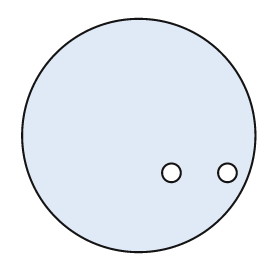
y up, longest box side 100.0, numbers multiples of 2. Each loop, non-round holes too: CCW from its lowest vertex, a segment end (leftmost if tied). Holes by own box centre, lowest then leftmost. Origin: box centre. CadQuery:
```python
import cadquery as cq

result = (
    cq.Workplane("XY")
    .moveTo(0.0, 0.0)
    .circle(50.0)
    .moveTo(14.0, -16.0)
    .circle(4.0)
    .moveTo(38.0, -16.0)
    .circle(4.0)
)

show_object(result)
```